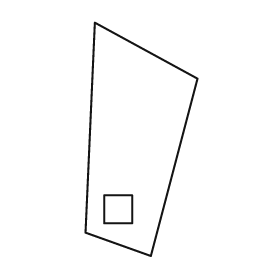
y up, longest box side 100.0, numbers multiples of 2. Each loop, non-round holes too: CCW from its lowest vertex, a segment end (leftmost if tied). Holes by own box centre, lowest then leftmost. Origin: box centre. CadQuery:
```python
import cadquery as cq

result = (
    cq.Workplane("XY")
    .moveTo(4.0, -50.0)
    .lineTo(24.0, 26.0)
    .lineTo(-20.0, 50.0)
    .lineTo(-24.0, -40.0)
    .close()
    .moveTo(-16.0, -36.0)
    .lineTo(-4.0, -36.0)
    .lineTo(-4.0, -24.0)
    .lineTo(-16.0, -24.0)
    .close()
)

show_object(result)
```